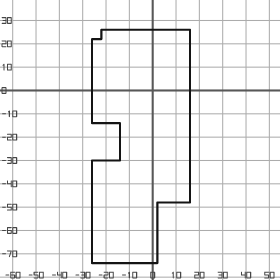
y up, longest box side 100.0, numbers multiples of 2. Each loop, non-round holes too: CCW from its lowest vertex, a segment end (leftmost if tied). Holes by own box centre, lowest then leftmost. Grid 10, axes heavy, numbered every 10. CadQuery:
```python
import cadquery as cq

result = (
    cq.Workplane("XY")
    .moveTo(-26.0, -74.0)
    .lineTo(2.0, -74.0)
    .lineTo(2.0, -48.0)
    .lineTo(16.0, -48.0)
    .lineTo(16.0, 26.0)
    .lineTo(-22.0, 26.0)
    .lineTo(-22.0, 22.0)
    .lineTo(-26.0, 22.0)
    .lineTo(-26.0, -14.0)
    .lineTo(-14.0, -14.0)
    .lineTo(-14.0, -30.0)
    .lineTo(-26.0, -30.0)
    .close()
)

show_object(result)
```